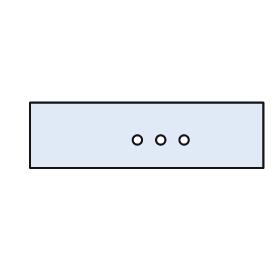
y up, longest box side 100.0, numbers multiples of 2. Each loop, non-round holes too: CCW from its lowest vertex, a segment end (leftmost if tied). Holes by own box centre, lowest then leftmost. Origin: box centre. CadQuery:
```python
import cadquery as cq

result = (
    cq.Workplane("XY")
    .moveTo(-50.0, -14.0)
    .lineTo(50.0, -14.0)
    .lineTo(50.0, 14.0)
    .lineTo(-50.0, 14.0)
    .close()
    .moveTo(-4.0, -2.0)
    .circle(2.0)
    .moveTo(6.0, -2.0)
    .circle(2.0)
    .moveTo(16.0, -2.0)
    .circle(2.0)
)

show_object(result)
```